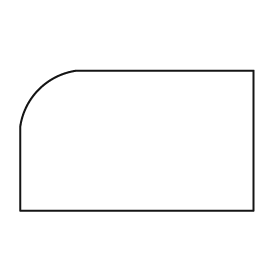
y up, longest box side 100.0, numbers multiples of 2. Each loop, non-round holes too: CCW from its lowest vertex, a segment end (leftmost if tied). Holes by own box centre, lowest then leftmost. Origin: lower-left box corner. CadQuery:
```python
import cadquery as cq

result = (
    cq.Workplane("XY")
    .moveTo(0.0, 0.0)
    .lineTo(100.0, 0.0)
    .lineTo(100.0, 60.0)
    .lineTo(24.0, 60.0)
    .threePointArc((8.0, 52.0), (0.0, 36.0))
    .close()
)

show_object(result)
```